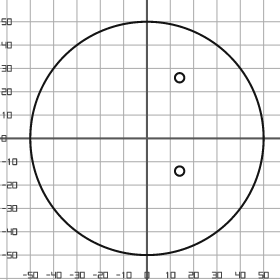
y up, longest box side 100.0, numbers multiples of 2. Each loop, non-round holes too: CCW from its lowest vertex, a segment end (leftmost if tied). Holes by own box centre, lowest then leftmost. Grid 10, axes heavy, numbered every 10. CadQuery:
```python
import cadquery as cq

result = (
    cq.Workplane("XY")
    .moveTo(0.0, 0.0)
    .circle(50.0)
    .moveTo(14.0, -14.0)
    .circle(2.0)
    .moveTo(14.0, 26.0)
    .circle(2.0)
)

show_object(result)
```